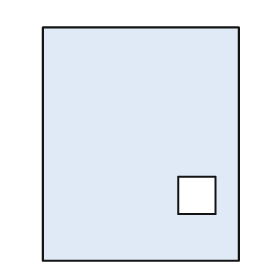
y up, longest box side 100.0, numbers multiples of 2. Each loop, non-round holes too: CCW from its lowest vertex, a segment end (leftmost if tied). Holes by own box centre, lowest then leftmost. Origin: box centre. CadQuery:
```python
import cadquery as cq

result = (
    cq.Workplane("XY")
    .moveTo(-42.0, -50.0)
    .lineTo(42.0, -50.0)
    .lineTo(42.0, 50.0)
    .lineTo(-42.0, 50.0)
    .close()
    .moveTo(16.0, -30.0)
    .lineTo(32.0, -30.0)
    .lineTo(32.0, -14.0)
    .lineTo(16.0, -14.0)
    .close()
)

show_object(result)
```